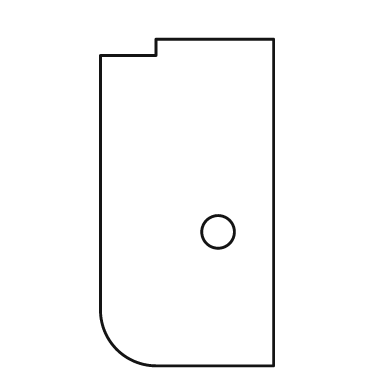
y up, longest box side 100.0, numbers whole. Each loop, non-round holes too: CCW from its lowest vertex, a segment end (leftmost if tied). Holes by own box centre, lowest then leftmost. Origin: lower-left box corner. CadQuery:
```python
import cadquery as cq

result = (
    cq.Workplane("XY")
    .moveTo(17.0, 0.0)
    .lineTo(53.0, 0.0)
    .lineTo(53.0, 100.0)
    .lineTo(17.0, 100.0)
    .lineTo(17.0, 95.0)
    .lineTo(0.0, 95.0)
    .lineTo(0.0, 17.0)
    .threePointArc((5.0, 5.0), (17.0, 0.0))
    .close()
    .moveTo(36.0, 41.0)
    .circle(5.0)
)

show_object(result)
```